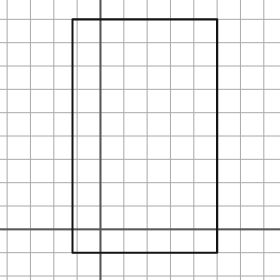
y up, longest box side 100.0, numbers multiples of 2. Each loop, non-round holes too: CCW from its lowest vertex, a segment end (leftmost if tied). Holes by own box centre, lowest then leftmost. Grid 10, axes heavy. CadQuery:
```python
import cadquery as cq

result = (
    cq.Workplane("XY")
    .moveTo(-12.0, -10.0)
    .lineTo(50.0, -10.0)
    .lineTo(50.0, 90.0)
    .lineTo(-12.0, 90.0)
    .close()
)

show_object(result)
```